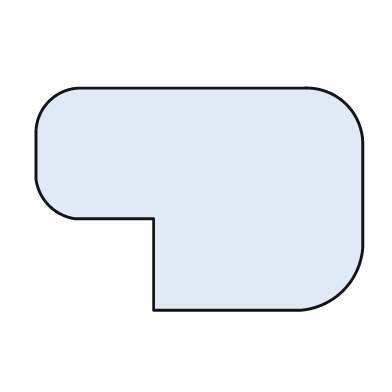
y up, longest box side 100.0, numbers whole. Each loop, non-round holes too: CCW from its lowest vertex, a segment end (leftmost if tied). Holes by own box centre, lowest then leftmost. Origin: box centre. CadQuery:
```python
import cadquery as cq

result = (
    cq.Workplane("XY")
    .moveTo(-14.0, -34.0)
    .lineTo(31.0, -34.0)
    .threePointArc((44.0, -28.0), (50.0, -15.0))
    .lineTo(50.0, 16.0)
    .threePointArc((45.0, 29.0), (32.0, 34.0))
    .lineTo(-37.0, 34.0)
    .threePointArc((-46.0, 30.0), (-50.0, 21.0))
    .lineTo(-50.0, 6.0)
    .threePointArc((-46.0, -2.0), (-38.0, -6.0))
    .lineTo(-14.0, -6.0)
    .close()
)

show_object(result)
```